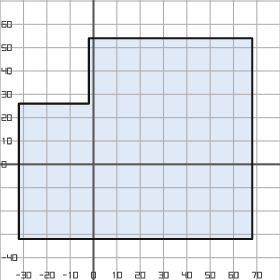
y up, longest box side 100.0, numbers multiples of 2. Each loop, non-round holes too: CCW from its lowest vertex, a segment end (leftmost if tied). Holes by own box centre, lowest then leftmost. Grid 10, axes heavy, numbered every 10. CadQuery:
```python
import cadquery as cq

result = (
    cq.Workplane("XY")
    .moveTo(-32.0, -32.0)
    .lineTo(68.0, -32.0)
    .lineTo(68.0, 54.0)
    .lineTo(-2.0, 54.0)
    .lineTo(-2.0, 26.0)
    .lineTo(-32.0, 26.0)
    .close()
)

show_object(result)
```